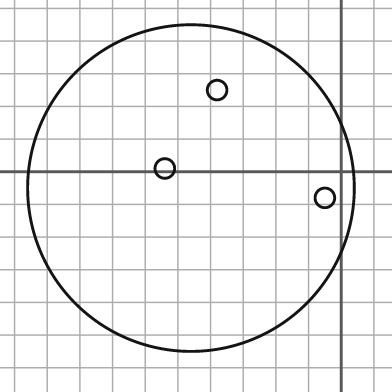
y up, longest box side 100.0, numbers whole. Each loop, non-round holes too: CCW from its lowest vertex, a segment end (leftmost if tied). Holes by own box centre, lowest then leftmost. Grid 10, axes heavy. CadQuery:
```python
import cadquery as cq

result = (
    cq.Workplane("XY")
    .moveTo(-46.0, -5.0)
    .circle(50.0)
    .moveTo(-5.0, -8.0)
    .circle(3.0)
    .moveTo(-54.0, 1.0)
    .circle(3.0)
    .moveTo(-38.0, 25.0)
    .circle(3.0)
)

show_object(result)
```